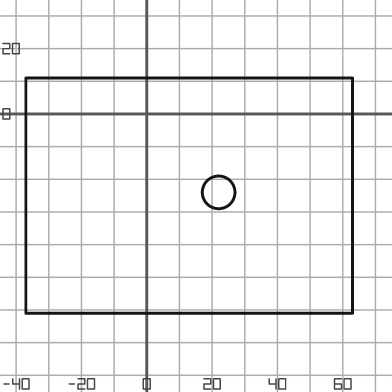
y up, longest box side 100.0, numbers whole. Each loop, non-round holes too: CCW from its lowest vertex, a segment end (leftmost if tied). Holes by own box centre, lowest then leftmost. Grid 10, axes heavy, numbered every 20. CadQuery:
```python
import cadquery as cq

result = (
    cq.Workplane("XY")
    .moveTo(-37.0, -61.0)
    .lineTo(63.0, -61.0)
    .lineTo(63.0, 11.0)
    .lineTo(-37.0, 11.0)
    .close()
    .moveTo(22.0, -24.0)
    .circle(5.0)
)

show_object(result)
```